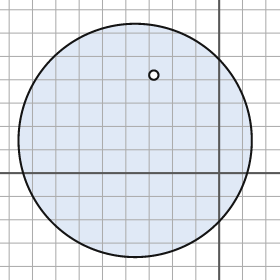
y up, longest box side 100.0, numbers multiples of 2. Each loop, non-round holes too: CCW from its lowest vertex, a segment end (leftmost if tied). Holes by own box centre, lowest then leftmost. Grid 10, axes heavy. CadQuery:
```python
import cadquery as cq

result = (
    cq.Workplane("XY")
    .moveTo(-36.0, 14.0)
    .circle(50.0)
    .moveTo(-28.0, 42.0)
    .circle(2.0)
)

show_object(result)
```